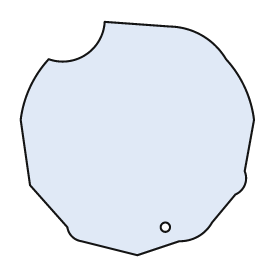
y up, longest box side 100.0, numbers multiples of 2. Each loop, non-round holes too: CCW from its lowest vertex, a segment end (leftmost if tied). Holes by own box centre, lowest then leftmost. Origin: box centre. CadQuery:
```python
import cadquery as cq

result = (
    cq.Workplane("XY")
    .moveTo(0.0, -50.0)
    .lineTo(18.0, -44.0)
    .threePointArc((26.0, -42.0), (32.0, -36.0))
    .lineTo(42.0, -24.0)
    .threePointArc((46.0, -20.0), (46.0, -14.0))
    .lineTo(50.0, 8.0)
    .threePointArc((46.0, 22.0), (38.0, 34.0))
    .threePointArc((28.0, 44.0), (14.0, 48.0))
    .lineTo(-14.0, 50.0)
    .threePointArc((-22.0, 36.0), (-38.0, 34.0))
    .threePointArc((-46.0, 22.0), (-50.0, 8.0))
    .lineTo(-46.0, -20.0)
    .lineTo(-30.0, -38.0)
    .threePointArc((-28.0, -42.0), (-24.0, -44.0))
    .close()
    .moveTo(12.0, -38.0)
    .circle(2.0)
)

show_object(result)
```